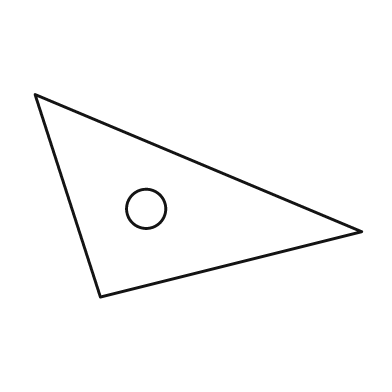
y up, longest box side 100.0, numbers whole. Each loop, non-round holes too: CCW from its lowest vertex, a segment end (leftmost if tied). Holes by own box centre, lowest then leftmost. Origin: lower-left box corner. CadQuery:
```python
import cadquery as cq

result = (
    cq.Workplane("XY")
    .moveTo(20.0, 0.0)
    .lineTo(100.0, 20.0)
    .lineTo(0.0, 62.0)
    .close()
    .moveTo(34.0, 27.0)
    .circle(6.0)
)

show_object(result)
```